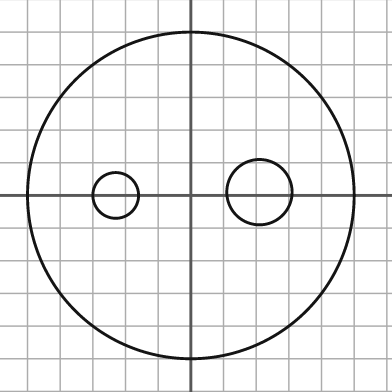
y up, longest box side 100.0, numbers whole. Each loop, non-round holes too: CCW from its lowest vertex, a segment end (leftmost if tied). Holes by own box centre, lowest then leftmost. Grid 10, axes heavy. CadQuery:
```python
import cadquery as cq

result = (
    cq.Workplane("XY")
    .moveTo(0.0, 0.0)
    .circle(50.0)
    .moveTo(-23.0, 0.0)
    .circle(7.0)
    .moveTo(21.0, 1.0)
    .circle(10.0)
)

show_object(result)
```